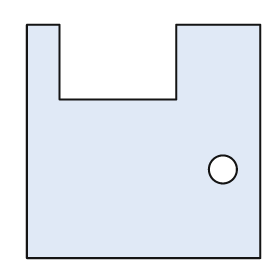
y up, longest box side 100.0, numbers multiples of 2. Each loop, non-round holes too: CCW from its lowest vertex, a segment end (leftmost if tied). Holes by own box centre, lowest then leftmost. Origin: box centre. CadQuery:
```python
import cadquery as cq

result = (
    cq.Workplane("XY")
    .moveTo(-50.0, -50.0)
    .lineTo(50.0, -50.0)
    .lineTo(50.0, 50.0)
    .lineTo(14.0, 50.0)
    .lineTo(14.0, 18.0)
    .lineTo(-36.0, 18.0)
    .lineTo(-36.0, 50.0)
    .lineTo(-50.0, 50.0)
    .close()
    .moveTo(34.0, -12.0)
    .circle(6.0)
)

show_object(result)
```